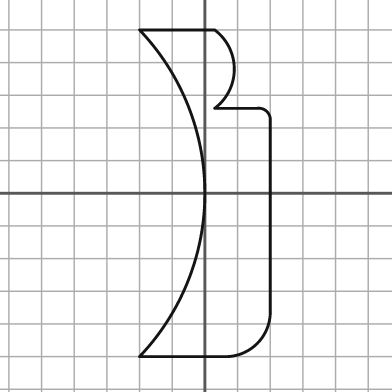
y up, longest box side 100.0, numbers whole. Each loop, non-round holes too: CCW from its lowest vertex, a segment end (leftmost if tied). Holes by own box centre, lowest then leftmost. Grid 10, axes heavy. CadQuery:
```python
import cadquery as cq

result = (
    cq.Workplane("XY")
    .moveTo(-20.0, -50.0)
    .lineTo(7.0, -50.0)
    .threePointArc((16.0, -46.0), (20.0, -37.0))
    .lineTo(20.0, 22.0)
    .threePointArc((19.0, 25.0), (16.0, 26.0))
    .lineTo(3.0, 26.0)
    .threePointArc((9.0, 38.0), (3.0, 50.0))
    .lineTo(-20.0, 50.0)
    .threePointArc((0.0, 0.0), (-20.0, -50.0))
    .close()
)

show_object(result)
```